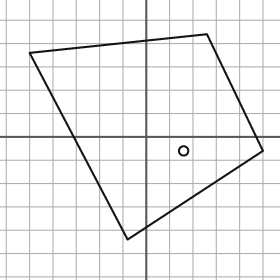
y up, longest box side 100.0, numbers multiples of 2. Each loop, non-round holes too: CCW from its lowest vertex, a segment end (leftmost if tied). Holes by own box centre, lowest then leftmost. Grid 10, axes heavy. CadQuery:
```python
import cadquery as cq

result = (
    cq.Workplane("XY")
    .moveTo(-8.0, -44.0)
    .lineTo(50.0, -6.0)
    .lineTo(26.0, 44.0)
    .lineTo(-50.0, 36.0)
    .close()
    .moveTo(16.0, -6.0)
    .circle(2.0)
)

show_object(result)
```